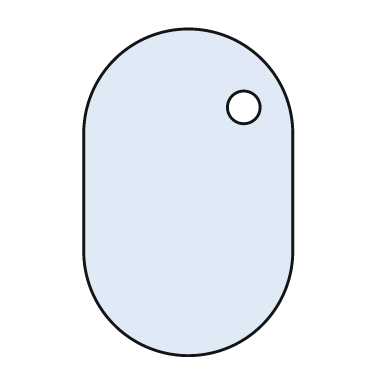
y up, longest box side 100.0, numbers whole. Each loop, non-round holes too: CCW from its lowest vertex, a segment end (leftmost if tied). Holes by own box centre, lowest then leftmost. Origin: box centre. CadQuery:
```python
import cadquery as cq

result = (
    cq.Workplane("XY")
    .moveTo(-32.0, -18.0)
    .threePointArc((0.0, -50.0), (32.0, -18.0))
    .lineTo(32.0, 18.0)
    .threePointArc((0.0, 50.0), (-32.0, 18.0))
    .close()
    .moveTo(17.0, 26.0)
    .circle(5.0)
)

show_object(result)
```